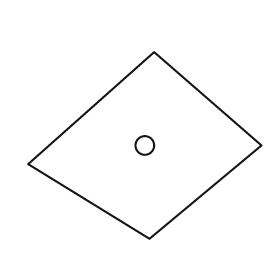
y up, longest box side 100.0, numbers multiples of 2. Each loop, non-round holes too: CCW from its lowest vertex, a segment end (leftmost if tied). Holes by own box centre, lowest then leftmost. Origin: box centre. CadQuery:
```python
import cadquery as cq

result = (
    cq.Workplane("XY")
    .moveTo(2.0, -40.0)
    .lineTo(50.0, 0.0)
    .lineTo(4.0, 40.0)
    .lineTo(-50.0, -8.0)
    .close()
    .moveTo(0.0, 0.0)
    .circle(4.0)
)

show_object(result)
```